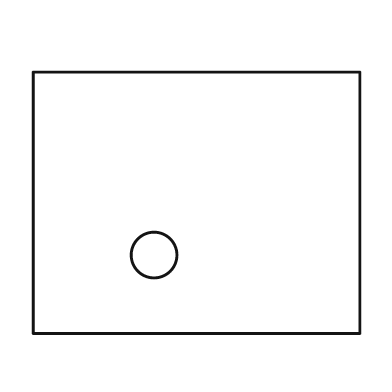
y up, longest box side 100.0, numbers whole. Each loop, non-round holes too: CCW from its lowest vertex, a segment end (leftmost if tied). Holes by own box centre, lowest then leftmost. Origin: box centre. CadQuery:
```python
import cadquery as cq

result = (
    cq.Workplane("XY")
    .moveTo(-50.0, -40.0)
    .lineTo(50.0, -40.0)
    .lineTo(50.0, 40.0)
    .lineTo(-50.0, 40.0)
    .close()
    .moveTo(-13.0, -16.0)
    .circle(7.0)
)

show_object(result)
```